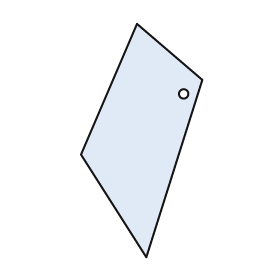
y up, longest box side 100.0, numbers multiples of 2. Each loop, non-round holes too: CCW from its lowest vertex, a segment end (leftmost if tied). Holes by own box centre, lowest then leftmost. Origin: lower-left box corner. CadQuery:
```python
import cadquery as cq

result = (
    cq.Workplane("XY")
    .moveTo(28.0, 0.0)
    .lineTo(52.0, 76.0)
    .lineTo(24.0, 100.0)
    .lineTo(0.0, 44.0)
    .close()
    .moveTo(44.0, 70.0)
    .circle(2.0)
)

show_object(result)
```